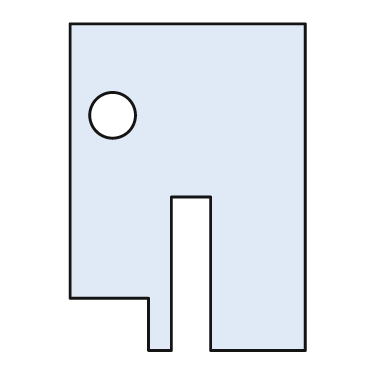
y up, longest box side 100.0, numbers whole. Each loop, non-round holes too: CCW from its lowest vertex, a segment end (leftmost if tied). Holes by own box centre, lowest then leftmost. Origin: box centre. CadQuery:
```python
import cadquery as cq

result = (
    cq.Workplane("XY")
    .moveTo(-12.0, -50.0)
    .lineTo(-5.0, -50.0)
    .lineTo(-5.0, -3.0)
    .lineTo(7.0, -3.0)
    .lineTo(7.0, -50.0)
    .lineTo(36.0, -50.0)
    .lineTo(36.0, 50.0)
    .lineTo(-36.0, 50.0)
    .lineTo(-36.0, -34.0)
    .lineTo(-12.0, -34.0)
    .close()
    .moveTo(-23.0, 22.0)
    .circle(7.0)
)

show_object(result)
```